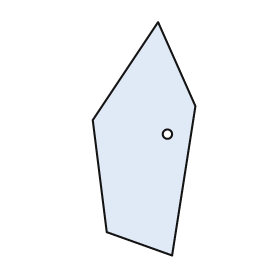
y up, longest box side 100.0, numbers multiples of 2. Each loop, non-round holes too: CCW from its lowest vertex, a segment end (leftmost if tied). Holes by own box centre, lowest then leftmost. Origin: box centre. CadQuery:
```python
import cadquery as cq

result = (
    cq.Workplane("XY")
    .moveTo(12.0, -50.0)
    .lineTo(22.0, 14.0)
    .lineTo(6.0, 50.0)
    .lineTo(-22.0, 8.0)
    .lineTo(-16.0, -40.0)
    .close()
    .moveTo(10.0, 2.0)
    .circle(2.0)
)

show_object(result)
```